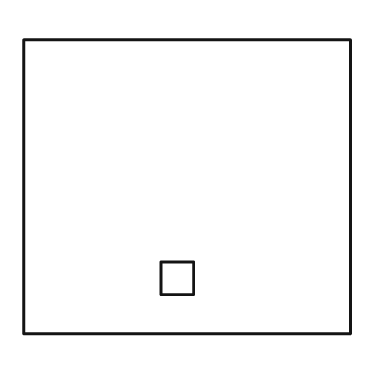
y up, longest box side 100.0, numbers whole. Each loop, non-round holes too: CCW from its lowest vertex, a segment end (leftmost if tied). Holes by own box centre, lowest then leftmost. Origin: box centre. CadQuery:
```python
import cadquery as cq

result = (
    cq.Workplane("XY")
    .moveTo(-50.0, -45.0)
    .lineTo(50.0, -45.0)
    .lineTo(50.0, 45.0)
    .lineTo(-50.0, 45.0)
    .close()
    .moveTo(-8.0, -33.0)
    .lineTo(2.0, -33.0)
    .lineTo(2.0, -23.0)
    .lineTo(-8.0, -23.0)
    .close()
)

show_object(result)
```